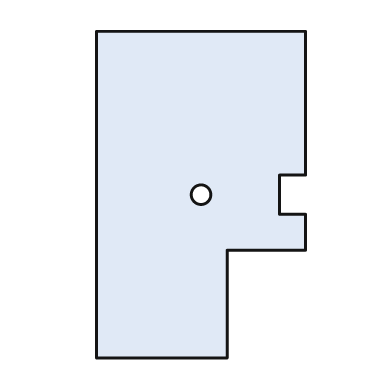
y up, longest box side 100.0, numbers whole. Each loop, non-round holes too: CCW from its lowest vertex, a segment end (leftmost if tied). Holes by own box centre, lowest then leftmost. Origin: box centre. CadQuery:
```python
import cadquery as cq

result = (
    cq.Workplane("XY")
    .moveTo(-32.0, -50.0)
    .lineTo(8.0, -50.0)
    .lineTo(8.0, -17.0)
    .lineTo(32.0, -17.0)
    .lineTo(32.0, -6.0)
    .lineTo(24.0, -6.0)
    .lineTo(24.0, 6.0)
    .lineTo(32.0, 6.0)
    .lineTo(32.0, 50.0)
    .lineTo(-32.0, 50.0)
    .close()
    .moveTo(0.0, 0.0)
    .circle(3.0)
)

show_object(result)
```